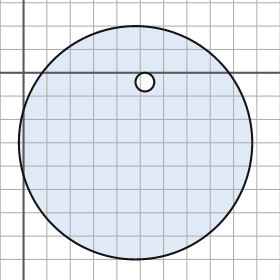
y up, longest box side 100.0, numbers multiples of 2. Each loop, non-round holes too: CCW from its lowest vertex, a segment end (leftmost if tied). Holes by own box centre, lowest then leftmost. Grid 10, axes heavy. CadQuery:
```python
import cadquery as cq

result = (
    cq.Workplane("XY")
    .moveTo(48.0, -30.0)
    .circle(50.0)
    .moveTo(52.0, -4.0)
    .circle(4.0)
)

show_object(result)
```